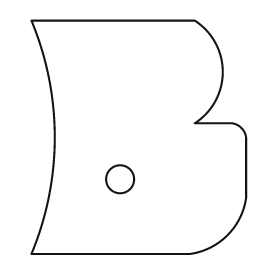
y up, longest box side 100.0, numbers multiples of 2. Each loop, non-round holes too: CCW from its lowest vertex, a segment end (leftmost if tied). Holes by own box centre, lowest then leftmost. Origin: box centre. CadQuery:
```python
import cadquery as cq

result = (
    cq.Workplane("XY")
    .moveTo(-46.0, -50.0)
    .lineTo(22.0, -50.0)
    .threePointArc((38.0, -42.0), (46.0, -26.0))
    .lineTo(46.0, 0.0)
    .threePointArc((44.0, 4.0), (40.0, 6.0))
    .lineTo(24.0, 6.0)
    .threePointArc((36.0, 28.0), (24.0, 50.0))
    .lineTo(-46.0, 50.0)
    .threePointArc((-36.0, 0.0), (-46.0, -50.0))
    .close()
    .moveTo(-8.0, -18.0)
    .circle(6.0)
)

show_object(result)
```